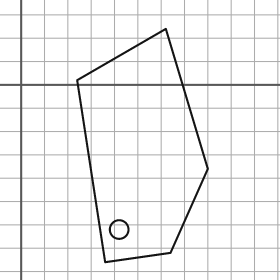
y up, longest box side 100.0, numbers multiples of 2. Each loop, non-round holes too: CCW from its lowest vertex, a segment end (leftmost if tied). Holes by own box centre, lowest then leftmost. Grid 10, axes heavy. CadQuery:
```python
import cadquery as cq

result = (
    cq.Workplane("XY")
    .moveTo(36.0, -76.0)
    .lineTo(64.0, -72.0)
    .lineTo(80.0, -36.0)
    .lineTo(62.0, 24.0)
    .lineTo(24.0, 2.0)
    .close()
    .moveTo(42.0, -62.0)
    .circle(4.0)
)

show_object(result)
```